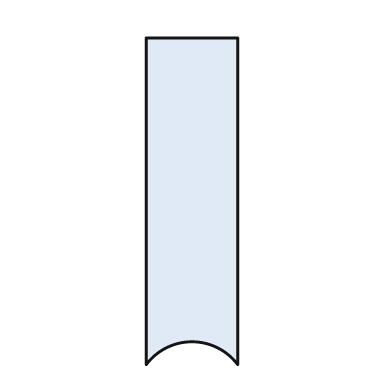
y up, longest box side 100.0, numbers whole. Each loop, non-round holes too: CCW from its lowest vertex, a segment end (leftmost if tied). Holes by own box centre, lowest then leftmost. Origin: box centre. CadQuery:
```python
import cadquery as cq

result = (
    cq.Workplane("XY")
    .moveTo(-14.0, -50.0)
    .threePointArc((0.0, -43.0), (14.0, -50.0))
    .lineTo(14.0, 50.0)
    .lineTo(-14.0, 50.0)
    .close()
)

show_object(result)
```